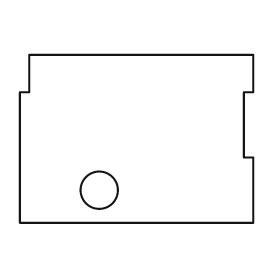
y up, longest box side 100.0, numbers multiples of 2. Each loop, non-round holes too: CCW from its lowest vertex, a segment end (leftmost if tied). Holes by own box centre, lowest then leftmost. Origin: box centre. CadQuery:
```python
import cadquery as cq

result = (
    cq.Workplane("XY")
    .moveTo(-50.0, -36.0)
    .lineTo(50.0, -36.0)
    .lineTo(50.0, -8.0)
    .lineTo(46.0, -8.0)
    .lineTo(46.0, 20.0)
    .lineTo(50.0, 20.0)
    .lineTo(50.0, 36.0)
    .lineTo(-46.0, 36.0)
    .lineTo(-46.0, 20.0)
    .lineTo(-50.0, 20.0)
    .close()
    .moveTo(-16.0, -22.0)
    .circle(8.0)
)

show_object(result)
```